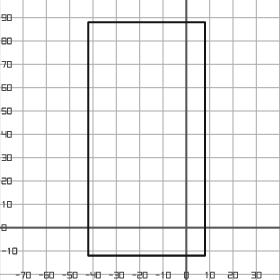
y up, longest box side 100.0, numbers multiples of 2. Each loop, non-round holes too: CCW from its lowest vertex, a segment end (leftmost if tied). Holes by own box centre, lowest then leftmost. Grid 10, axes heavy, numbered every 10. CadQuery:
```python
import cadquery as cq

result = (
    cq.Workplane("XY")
    .moveTo(-42.0, -12.0)
    .lineTo(8.0, -12.0)
    .lineTo(8.0, 88.0)
    .lineTo(-42.0, 88.0)
    .close()
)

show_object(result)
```